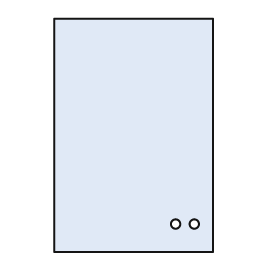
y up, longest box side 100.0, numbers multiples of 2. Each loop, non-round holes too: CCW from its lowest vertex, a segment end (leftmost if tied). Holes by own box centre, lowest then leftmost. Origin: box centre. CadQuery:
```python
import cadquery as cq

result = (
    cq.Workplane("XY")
    .moveTo(-34.0, -50.0)
    .lineTo(34.0, -50.0)
    .lineTo(34.0, 50.0)
    .lineTo(-34.0, 50.0)
    .close()
    .moveTo(18.0, -38.0)
    .circle(2.0)
    .moveTo(26.0, -38.0)
    .circle(2.0)
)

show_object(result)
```